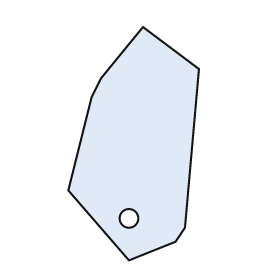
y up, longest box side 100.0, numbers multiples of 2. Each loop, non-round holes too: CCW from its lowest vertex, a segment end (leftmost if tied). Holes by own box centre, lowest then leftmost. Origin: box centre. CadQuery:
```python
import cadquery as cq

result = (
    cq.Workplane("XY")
    .moveTo(-2.0, -50.0)
    .lineTo(18.0, -42.0)
    .lineTo(22.0, -36.0)
    .lineTo(28.0, 32.0)
    .lineTo(4.0, 50.0)
    .lineTo(-14.0, 28.0)
    .lineTo(-18.0, 20.0)
    .lineTo(-28.0, -20.0)
    .close()
    .moveTo(-2.0, -32.0)
    .circle(4.0)
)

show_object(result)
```